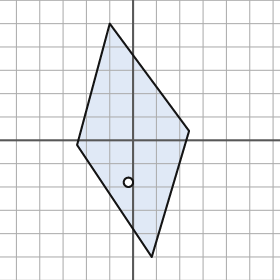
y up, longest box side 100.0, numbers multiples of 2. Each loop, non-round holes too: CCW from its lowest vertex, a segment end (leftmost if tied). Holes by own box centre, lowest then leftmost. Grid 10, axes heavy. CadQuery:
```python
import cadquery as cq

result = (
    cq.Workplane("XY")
    .moveTo(8.0, -50.0)
    .lineTo(24.0, 4.0)
    .lineTo(-10.0, 50.0)
    .lineTo(-24.0, -2.0)
    .close()
    .moveTo(-2.0, -18.0)
    .circle(2.0)
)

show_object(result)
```